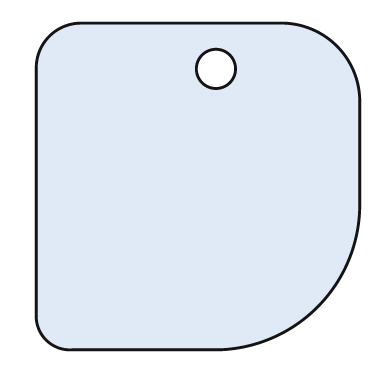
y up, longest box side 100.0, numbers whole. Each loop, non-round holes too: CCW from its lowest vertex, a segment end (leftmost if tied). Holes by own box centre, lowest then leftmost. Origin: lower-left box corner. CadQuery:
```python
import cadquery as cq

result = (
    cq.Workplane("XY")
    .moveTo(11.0, 0.0)
    .lineTo(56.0, 0.0)
    .threePointArc((86.0, 13.0), (99.0, 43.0))
    .lineTo(99.0, 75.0)
    .threePointArc((92.0, 93.0), (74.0, 100.0))
    .lineTo(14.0, 100.0)
    .threePointArc((4.0, 96.0), (0.0, 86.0))
    .lineTo(0.0, 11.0)
    .threePointArc((3.0, 3.0), (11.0, 0.0))
    .close()
    .moveTo(55.0, 86.0)
    .circle(6.0)
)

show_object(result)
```